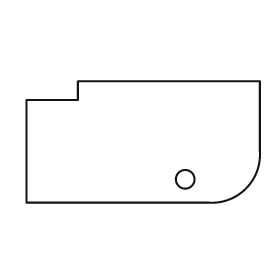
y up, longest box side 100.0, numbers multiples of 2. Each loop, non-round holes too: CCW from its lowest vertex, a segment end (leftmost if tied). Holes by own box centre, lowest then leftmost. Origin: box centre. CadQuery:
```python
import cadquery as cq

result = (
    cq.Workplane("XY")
    .moveTo(-50.0, -26.0)
    .lineTo(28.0, -26.0)
    .threePointArc((44.0, -20.0), (50.0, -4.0))
    .lineTo(50.0, 26.0)
    .lineTo(-28.0, 26.0)
    .lineTo(-28.0, 18.0)
    .lineTo(-50.0, 18.0)
    .close()
    .moveTo(18.0, -16.0)
    .circle(4.0)
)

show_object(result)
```